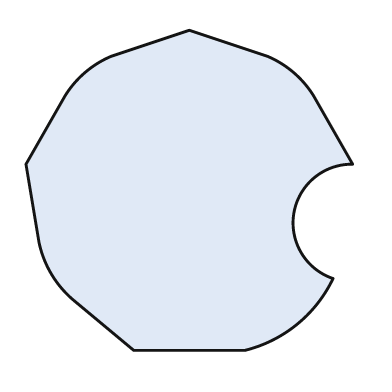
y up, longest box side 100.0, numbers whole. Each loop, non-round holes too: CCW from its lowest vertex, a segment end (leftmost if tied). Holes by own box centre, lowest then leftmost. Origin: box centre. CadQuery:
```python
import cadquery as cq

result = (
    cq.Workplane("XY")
    .moveTo(-17.0, -49.0)
    .lineTo(17.0, -49.0)
    .threePointArc((33.0, -41.0), (44.0, -27.0))
    .threePointArc((32.0, -7.0), (50.0, 8.0))
    .lineTo(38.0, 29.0)
    .threePointArc((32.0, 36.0), (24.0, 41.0))
    .lineTo(0.0, 49.0)
    .lineTo(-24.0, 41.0)
    .threePointArc((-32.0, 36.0), (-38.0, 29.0))
    .lineTo(-50.0, 8.0)
    .lineTo(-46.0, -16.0)
    .threePointArc((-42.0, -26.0), (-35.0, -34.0))
    .close()
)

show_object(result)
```